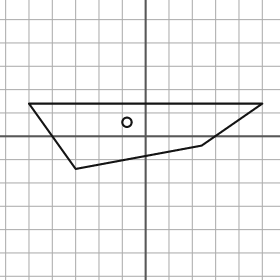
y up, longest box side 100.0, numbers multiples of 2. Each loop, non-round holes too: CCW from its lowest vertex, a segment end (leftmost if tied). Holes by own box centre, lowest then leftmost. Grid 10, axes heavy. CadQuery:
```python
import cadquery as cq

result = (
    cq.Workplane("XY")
    .moveTo(-30.0, -14.0)
    .lineTo(24.0, -4.0)
    .lineTo(50.0, 14.0)
    .lineTo(-50.0, 14.0)
    .close()
    .moveTo(-8.0, 6.0)
    .circle(2.0)
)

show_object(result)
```